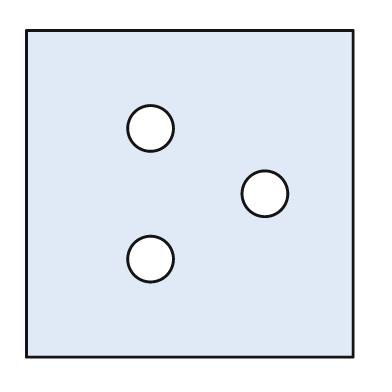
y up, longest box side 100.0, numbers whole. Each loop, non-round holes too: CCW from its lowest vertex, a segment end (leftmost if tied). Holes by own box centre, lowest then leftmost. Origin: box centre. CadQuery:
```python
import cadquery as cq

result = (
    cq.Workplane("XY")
    .moveTo(-50.0, -50.0)
    .lineTo(50.0, -50.0)
    .lineTo(50.0, 50.0)
    .lineTo(-50.0, 50.0)
    .close()
    .moveTo(-12.0, -20.0)
    .circle(7.0)
    .moveTo(23.0, 0.0)
    .circle(7.0)
    .moveTo(-12.0, 20.0)
    .circle(7.0)
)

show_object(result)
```